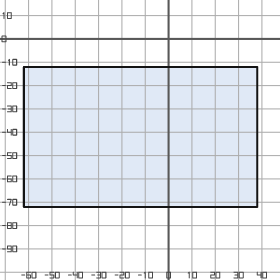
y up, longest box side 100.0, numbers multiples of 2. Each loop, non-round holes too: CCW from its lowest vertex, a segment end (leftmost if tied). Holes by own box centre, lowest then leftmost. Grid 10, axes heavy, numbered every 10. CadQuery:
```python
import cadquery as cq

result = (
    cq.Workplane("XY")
    .moveTo(-62.0, -72.0)
    .lineTo(38.0, -72.0)
    .lineTo(38.0, -12.0)
    .lineTo(-62.0, -12.0)
    .close()
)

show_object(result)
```